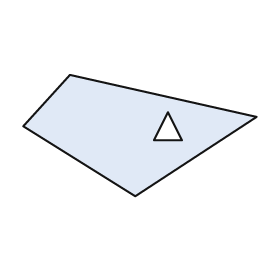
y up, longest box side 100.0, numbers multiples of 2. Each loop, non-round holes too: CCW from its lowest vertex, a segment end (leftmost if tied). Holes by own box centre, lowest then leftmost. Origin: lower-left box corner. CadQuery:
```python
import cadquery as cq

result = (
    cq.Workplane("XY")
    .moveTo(48.0, 0.0)
    .lineTo(100.0, 34.0)
    .lineTo(20.0, 52.0)
    .lineTo(0.0, 30.0)
    .close()
    .moveTo(56.0, 24.0)
    .lineTo(68.0, 24.0)
    .lineTo(62.0, 36.0)
    .close()
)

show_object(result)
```